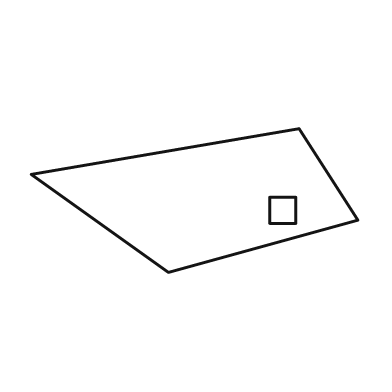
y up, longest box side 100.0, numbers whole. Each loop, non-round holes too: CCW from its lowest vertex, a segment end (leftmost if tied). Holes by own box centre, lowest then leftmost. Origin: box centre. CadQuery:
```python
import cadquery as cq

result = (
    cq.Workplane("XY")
    .moveTo(-8.0, -22.0)
    .lineTo(50.0, -6.0)
    .lineTo(32.0, 22.0)
    .lineTo(-50.0, 8.0)
    .close()
    .moveTo(23.0, -7.0)
    .lineTo(31.0, -7.0)
    .lineTo(31.0, 1.0)
    .lineTo(23.0, 1.0)
    .close()
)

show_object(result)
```